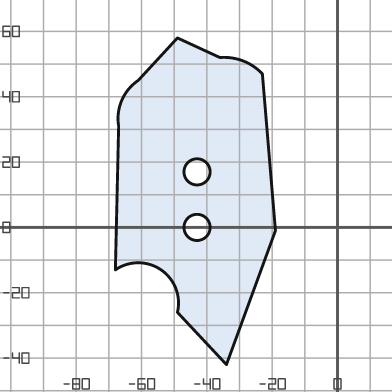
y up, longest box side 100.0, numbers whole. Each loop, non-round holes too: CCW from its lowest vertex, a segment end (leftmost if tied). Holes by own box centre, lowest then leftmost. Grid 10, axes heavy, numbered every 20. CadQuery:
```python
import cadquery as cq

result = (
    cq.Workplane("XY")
    .moveTo(-34.0, -42.0)
    .lineTo(-19.0, -1.0)
    .lineTo(-23.0, 47.0)
    .threePointArc((-29.0, 51.0), (-36.0, 52.0))
    .lineTo(-49.0, 58.0)
    .lineTo(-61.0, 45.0)
    .threePointArc((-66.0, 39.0), (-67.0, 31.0))
    .lineTo(-68.0, -13.0)
    .threePointArc((-54.0, -13.0), (-49.0, -26.0))
    .close()
    .moveTo(-43.0, 0.0)
    .circle(4.0)
    .moveTo(-43.0, 17.0)
    .circle(4.0)
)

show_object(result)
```